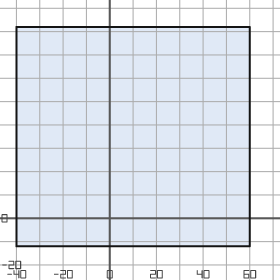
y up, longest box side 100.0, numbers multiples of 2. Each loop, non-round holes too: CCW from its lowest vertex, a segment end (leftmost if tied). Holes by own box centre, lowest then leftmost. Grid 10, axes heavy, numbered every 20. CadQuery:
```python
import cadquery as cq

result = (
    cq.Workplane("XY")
    .moveTo(-40.0, -12.0)
    .lineTo(60.0, -12.0)
    .lineTo(60.0, 82.0)
    .lineTo(-40.0, 82.0)
    .close()
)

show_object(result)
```